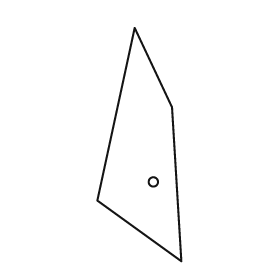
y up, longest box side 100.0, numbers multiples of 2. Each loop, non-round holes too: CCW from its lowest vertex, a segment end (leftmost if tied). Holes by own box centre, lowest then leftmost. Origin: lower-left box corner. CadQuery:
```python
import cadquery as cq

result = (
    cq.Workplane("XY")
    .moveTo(36.0, 0.0)
    .lineTo(32.0, 66.0)
    .lineTo(16.0, 100.0)
    .lineTo(0.0, 26.0)
    .close()
    .moveTo(24.0, 34.0)
    .circle(2.0)
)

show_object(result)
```